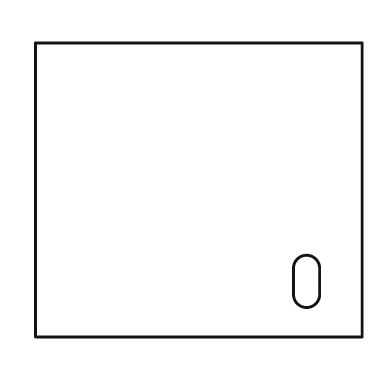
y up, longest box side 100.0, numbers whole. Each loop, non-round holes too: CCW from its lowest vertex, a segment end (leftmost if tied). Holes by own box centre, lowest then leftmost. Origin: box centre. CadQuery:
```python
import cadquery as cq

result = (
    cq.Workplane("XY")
    .moveTo(-50.0, -45.0)
    .lineTo(50.0, -45.0)
    .lineTo(50.0, 45.0)
    .lineTo(-50.0, 45.0)
    .close()
    .moveTo(29.0, -32.0)
    .threePointArc((33.0, -36.0), (37.0, -32.0))
    .lineTo(37.0, -24.0)
    .threePointArc((33.0, -20.0), (29.0, -24.0))
    .close()
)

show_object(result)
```